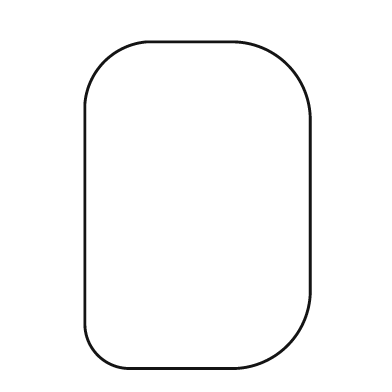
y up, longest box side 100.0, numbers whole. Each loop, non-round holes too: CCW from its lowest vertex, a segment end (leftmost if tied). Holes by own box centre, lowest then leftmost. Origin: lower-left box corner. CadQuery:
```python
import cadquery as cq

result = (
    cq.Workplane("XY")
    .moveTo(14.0, 0.0)
    .lineTo(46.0, 0.0)
    .threePointArc((62.0, 7.0), (69.0, 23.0))
    .lineTo(69.0, 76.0)
    .threePointArc((62.0, 93.0), (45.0, 100.0))
    .lineTo(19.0, 100.0)
    .threePointArc((6.0, 94.0), (0.0, 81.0))
    .lineTo(0.0, 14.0)
    .threePointArc((4.0, 4.0), (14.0, 0.0))
    .close()
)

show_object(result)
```